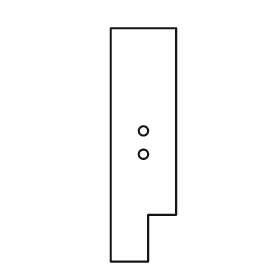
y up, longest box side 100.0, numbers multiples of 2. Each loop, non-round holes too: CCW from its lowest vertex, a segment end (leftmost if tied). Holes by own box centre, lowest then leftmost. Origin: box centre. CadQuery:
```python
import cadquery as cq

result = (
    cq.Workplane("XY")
    .moveTo(-14.0, -50.0)
    .lineTo(2.0, -50.0)
    .lineTo(2.0, -30.0)
    .lineTo(14.0, -30.0)
    .lineTo(14.0, 50.0)
    .lineTo(-14.0, 50.0)
    .close()
    .moveTo(0.0, -4.0)
    .circle(2.0)
    .moveTo(0.0, 6.0)
    .circle(2.0)
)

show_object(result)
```